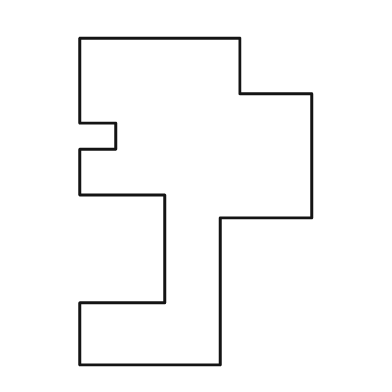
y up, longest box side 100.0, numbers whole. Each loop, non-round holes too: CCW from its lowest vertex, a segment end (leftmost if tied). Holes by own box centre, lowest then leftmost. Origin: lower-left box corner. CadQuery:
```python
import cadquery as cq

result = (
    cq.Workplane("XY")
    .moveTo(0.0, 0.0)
    .lineTo(43.0, 0.0)
    .lineTo(43.0, 45.0)
    .lineTo(71.0, 45.0)
    .lineTo(71.0, 83.0)
    .lineTo(49.0, 83.0)
    .lineTo(49.0, 100.0)
    .lineTo(0.0, 100.0)
    .lineTo(0.0, 74.0)
    .lineTo(11.0, 74.0)
    .lineTo(11.0, 66.0)
    .lineTo(0.0, 66.0)
    .lineTo(0.0, 52.0)
    .lineTo(26.0, 52.0)
    .lineTo(26.0, 19.0)
    .lineTo(0.0, 19.0)
    .close()
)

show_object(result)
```